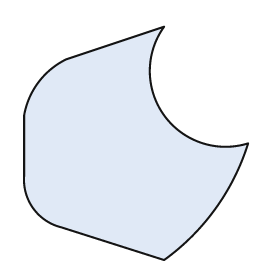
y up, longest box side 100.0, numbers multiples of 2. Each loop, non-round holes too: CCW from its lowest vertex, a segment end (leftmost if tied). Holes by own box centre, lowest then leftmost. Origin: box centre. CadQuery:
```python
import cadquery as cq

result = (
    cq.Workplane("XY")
    .moveTo(12.0, -50.0)
    .threePointArc((34.0, -28.0), (48.0, 0.0))
    .threePointArc((12.0, 12.0), (12.0, 50.0))
    .lineTo(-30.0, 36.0)
    .threePointArc((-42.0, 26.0), (-48.0, 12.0))
    .lineTo(-48.0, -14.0)
    .threePointArc((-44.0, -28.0), (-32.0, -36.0))
    .close()
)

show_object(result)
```